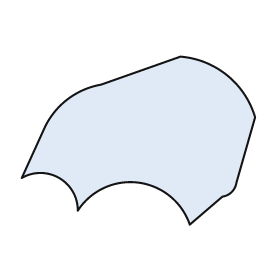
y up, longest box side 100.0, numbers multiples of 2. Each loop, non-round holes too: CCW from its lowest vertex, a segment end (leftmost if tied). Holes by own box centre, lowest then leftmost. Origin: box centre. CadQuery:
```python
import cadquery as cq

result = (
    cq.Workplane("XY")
    .moveTo(22.0, -36.0)
    .lineTo(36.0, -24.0)
    .threePointArc((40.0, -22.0), (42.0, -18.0))
    .lineTo(50.0, 10.0)
    .threePointArc((38.0, 28.0), (18.0, 36.0))
    .lineTo(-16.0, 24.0)
    .threePointArc((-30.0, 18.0), (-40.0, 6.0))
    .lineTo(-50.0, -16.0)
    .threePointArc((-34.0, -16.0), (-26.0, -30.0))
    .threePointArc((0.0, -18.0), (22.0, -36.0))
    .close()
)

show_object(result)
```